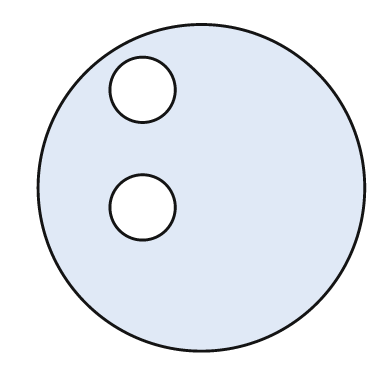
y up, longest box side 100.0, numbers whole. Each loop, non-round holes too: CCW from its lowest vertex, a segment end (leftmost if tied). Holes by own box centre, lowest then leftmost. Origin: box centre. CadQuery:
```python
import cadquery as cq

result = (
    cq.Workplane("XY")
    .moveTo(0.0, 0.0)
    .circle(50.0)
    .moveTo(-18.0, -6.0)
    .circle(10.0)
    .moveTo(-18.0, 30.0)
    .circle(10.0)
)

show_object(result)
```